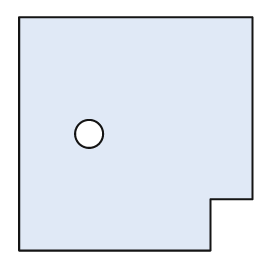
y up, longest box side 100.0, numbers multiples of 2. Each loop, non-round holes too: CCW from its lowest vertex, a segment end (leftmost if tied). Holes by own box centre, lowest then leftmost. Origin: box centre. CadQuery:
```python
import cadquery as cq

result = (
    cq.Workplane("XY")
    .moveTo(-50.0, -50.0)
    .lineTo(32.0, -50.0)
    .lineTo(32.0, -28.0)
    .lineTo(50.0, -28.0)
    .lineTo(50.0, 50.0)
    .lineTo(-50.0, 50.0)
    .close()
    .moveTo(-20.0, 0.0)
    .circle(6.0)
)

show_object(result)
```